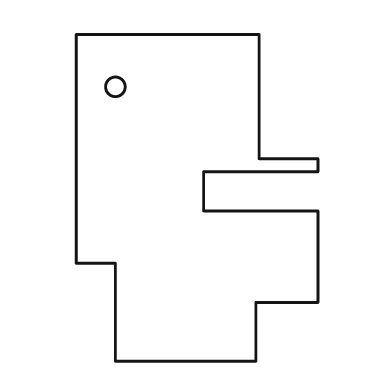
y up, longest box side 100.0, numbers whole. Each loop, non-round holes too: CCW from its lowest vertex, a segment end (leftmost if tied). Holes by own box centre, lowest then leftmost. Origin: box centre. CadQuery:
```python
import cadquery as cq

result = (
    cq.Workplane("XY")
    .moveTo(-25.0, -50.0)
    .lineTo(18.0, -50.0)
    .lineTo(18.0, -32.0)
    .lineTo(37.0, -32.0)
    .lineTo(37.0, -4.0)
    .lineTo(2.0, -4.0)
    .lineTo(2.0, 8.0)
    .lineTo(37.0, 8.0)
    .lineTo(37.0, 12.0)
    .lineTo(19.0, 12.0)
    .lineTo(19.0, 50.0)
    .lineTo(-37.0, 50.0)
    .lineTo(-37.0, -20.0)
    .lineTo(-25.0, -20.0)
    .close()
    .moveTo(-25.0, 34.0)
    .circle(3.0)
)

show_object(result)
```